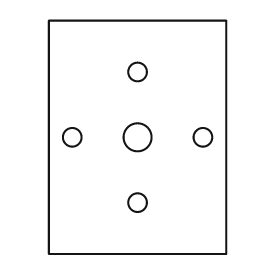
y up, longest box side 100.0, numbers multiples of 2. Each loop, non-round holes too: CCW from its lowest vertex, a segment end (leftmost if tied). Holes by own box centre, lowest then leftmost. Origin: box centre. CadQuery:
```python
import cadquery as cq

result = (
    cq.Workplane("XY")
    .moveTo(-38.0, -50.0)
    .lineTo(38.0, -50.0)
    .lineTo(38.0, 50.0)
    .lineTo(-38.0, 50.0)
    .close()
    .moveTo(0.0, -28.0)
    .circle(4.0)
    .moveTo(-28.0, 0.0)
    .circle(4.0)
    .moveTo(0.0, 0.0)
    .circle(6.0)
    .moveTo(28.0, 0.0)
    .circle(4.0)
    .moveTo(0.0, 28.0)
    .circle(4.0)
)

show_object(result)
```